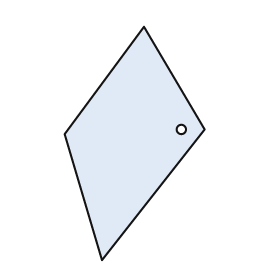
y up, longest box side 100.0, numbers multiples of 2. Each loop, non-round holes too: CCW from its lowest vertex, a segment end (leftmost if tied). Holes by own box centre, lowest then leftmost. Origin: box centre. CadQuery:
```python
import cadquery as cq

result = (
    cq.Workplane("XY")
    .moveTo(-14.0, -50.0)
    .lineTo(30.0, 6.0)
    .lineTo(4.0, 50.0)
    .lineTo(-30.0, 4.0)
    .close()
    .moveTo(20.0, 6.0)
    .circle(2.0)
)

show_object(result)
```